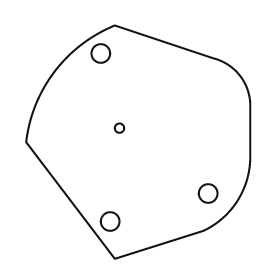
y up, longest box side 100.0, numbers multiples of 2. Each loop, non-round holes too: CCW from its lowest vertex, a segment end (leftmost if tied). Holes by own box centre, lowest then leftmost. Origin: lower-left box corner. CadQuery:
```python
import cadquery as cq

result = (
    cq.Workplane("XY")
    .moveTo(38.0, 0.0)
    .lineTo(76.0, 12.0)
    .threePointArc((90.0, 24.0), (96.0, 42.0))
    .lineTo(96.0, 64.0)
    .threePointArc((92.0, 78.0), (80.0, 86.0))
    .lineTo(38.0, 100.0)
    .threePointArc((12.0, 80.0), (0.0, 50.0))
    .close()
    .moveTo(36.0, 16.0)
    .circle(4.0)
    .moveTo(78.0, 28.0)
    .circle(4.0)
    .moveTo(40.0, 56.0)
    .circle(2.0)
    .moveTo(32.0, 88.0)
    .circle(4.0)
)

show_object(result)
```